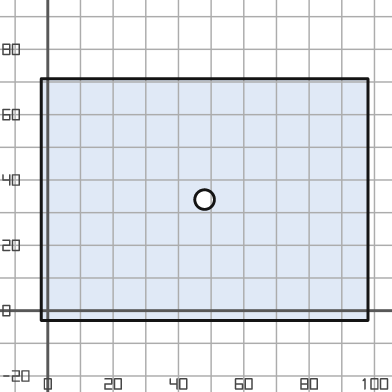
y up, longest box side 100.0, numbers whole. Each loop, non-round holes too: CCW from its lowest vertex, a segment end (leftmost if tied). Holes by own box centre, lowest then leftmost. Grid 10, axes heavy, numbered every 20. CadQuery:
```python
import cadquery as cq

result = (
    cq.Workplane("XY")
    .moveTo(-2.0, -3.0)
    .lineTo(98.0, -3.0)
    .lineTo(98.0, 71.0)
    .lineTo(-2.0, 71.0)
    .close()
    .moveTo(48.0, 34.0)
    .circle(3.0)
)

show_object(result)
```